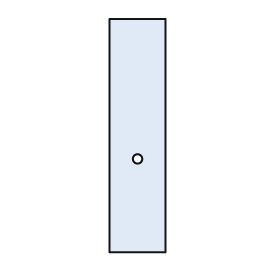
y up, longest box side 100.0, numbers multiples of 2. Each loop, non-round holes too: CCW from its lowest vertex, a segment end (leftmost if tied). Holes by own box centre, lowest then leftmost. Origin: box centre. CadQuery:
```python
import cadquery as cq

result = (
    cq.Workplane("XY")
    .moveTo(-12.0, -50.0)
    .lineTo(12.0, -50.0)
    .lineTo(12.0, 50.0)
    .lineTo(-12.0, 50.0)
    .close()
    .moveTo(0.0, -10.0)
    .circle(2.0)
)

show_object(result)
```